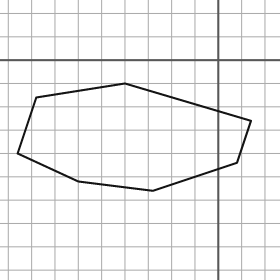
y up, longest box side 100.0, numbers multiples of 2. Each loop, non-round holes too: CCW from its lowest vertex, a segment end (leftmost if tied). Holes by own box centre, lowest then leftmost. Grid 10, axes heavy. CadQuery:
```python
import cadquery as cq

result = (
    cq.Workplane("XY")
    .moveTo(-28.0, -56.0)
    .lineTo(8.0, -44.0)
    .lineTo(14.0, -26.0)
    .lineTo(-40.0, -10.0)
    .lineTo(-78.0, -16.0)
    .lineTo(-86.0, -40.0)
    .lineTo(-60.0, -52.0)
    .close()
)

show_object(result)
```